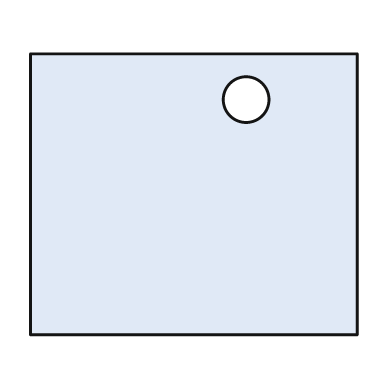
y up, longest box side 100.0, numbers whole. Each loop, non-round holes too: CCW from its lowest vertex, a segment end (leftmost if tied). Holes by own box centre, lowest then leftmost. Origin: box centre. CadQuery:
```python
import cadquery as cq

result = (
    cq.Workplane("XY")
    .moveTo(-50.0, -43.0)
    .lineTo(50.0, -43.0)
    .lineTo(50.0, 43.0)
    .lineTo(-50.0, 43.0)
    .close()
    .moveTo(16.0, 29.0)
    .circle(7.0)
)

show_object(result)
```